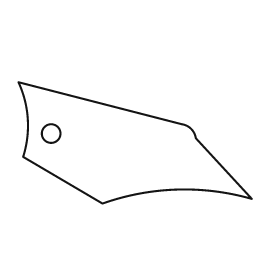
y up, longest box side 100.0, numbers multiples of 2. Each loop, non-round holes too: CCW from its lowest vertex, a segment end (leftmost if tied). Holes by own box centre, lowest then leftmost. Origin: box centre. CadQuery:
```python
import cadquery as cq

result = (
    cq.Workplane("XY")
    .moveTo(-14.0, -26.0)
    .threePointArc((18.0, -20.0), (50.0, -24.0))
    .lineTo(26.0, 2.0)
    .threePointArc((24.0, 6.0), (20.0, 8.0))
    .lineTo(-50.0, 26.0)
    .threePointArc((-46.0, 10.0), (-48.0, -6.0))
    .close()
    .moveTo(-36.0, 4.0)
    .circle(4.0)
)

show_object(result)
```